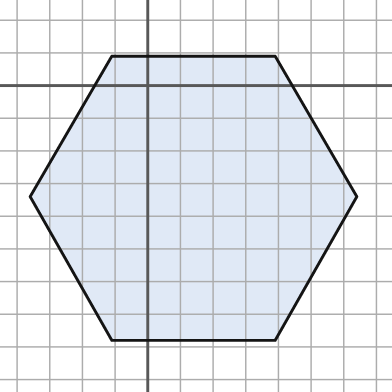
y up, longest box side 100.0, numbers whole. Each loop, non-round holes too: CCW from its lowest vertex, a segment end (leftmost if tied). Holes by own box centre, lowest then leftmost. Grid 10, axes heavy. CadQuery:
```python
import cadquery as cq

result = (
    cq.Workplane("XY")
    .moveTo(-11.0, -78.0)
    .lineTo(39.0, -78.0)
    .lineTo(64.0, -34.0)
    .lineTo(39.0, 9.0)
    .lineTo(-11.0, 9.0)
    .lineTo(-36.0, -34.0)
    .close()
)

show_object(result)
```